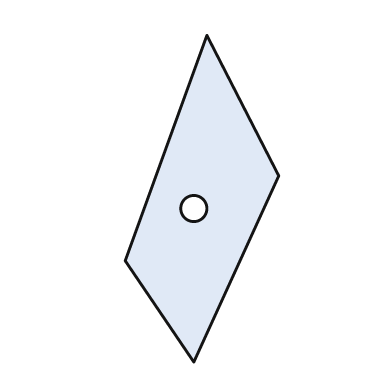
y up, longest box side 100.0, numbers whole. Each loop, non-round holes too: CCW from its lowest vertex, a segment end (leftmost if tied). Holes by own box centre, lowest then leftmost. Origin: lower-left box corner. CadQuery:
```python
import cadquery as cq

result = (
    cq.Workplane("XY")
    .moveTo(21.0, 0.0)
    .lineTo(47.0, 57.0)
    .lineTo(25.0, 100.0)
    .lineTo(0.0, 31.0)
    .close()
    .moveTo(21.0, 47.0)
    .circle(4.0)
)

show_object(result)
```